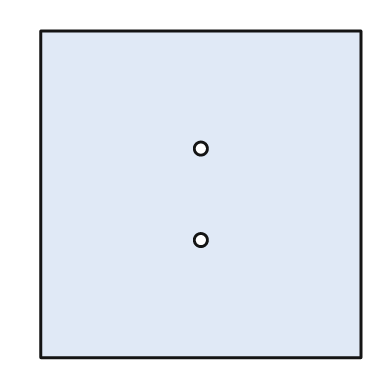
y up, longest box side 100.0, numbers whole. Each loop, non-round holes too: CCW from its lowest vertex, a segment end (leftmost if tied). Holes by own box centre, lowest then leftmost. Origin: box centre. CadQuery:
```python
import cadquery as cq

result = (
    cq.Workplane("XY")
    .moveTo(-49.0, -50.0)
    .lineTo(49.0, -50.0)
    .lineTo(49.0, 50.0)
    .lineTo(-49.0, 50.0)
    .close()
    .moveTo(0.0, -14.0)
    .circle(2.0)
    .moveTo(0.0, 14.0)
    .circle(2.0)
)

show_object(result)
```